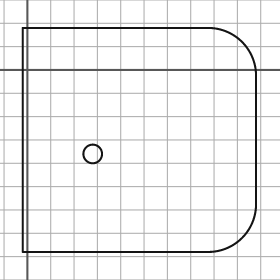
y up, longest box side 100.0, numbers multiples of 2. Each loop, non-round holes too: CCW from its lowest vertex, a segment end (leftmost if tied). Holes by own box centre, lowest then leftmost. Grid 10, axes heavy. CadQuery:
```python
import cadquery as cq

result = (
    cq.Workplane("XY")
    .moveTo(-2.0, -78.0)
    .lineTo(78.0, -78.0)
    .threePointArc((92.0, -72.0), (98.0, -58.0))
    .lineTo(98.0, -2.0)
    .threePointArc((92.0, 12.0), (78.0, 18.0))
    .lineTo(-2.0, 18.0)
    .close()
    .moveTo(28.0, -36.0)
    .circle(4.0)
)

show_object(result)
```